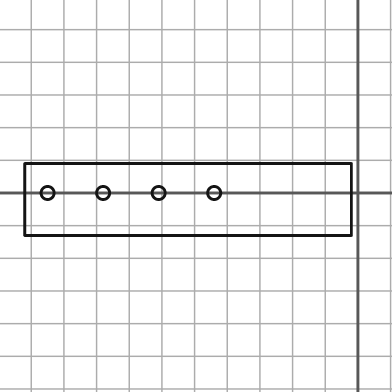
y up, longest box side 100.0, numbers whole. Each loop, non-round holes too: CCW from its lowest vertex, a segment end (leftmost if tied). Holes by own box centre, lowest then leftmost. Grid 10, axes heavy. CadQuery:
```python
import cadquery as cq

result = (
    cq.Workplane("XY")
    .moveTo(-102.0, -13.0)
    .lineTo(-2.0, -13.0)
    .lineTo(-2.0, 9.0)
    .lineTo(-102.0, 9.0)
    .close()
    .moveTo(-95.0, 0.0)
    .circle(2.0)
    .moveTo(-78.0, 0.0)
    .circle(2.0)
    .moveTo(-61.0, 0.0)
    .circle(2.0)
    .moveTo(-44.0, 0.0)
    .circle(2.0)
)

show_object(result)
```